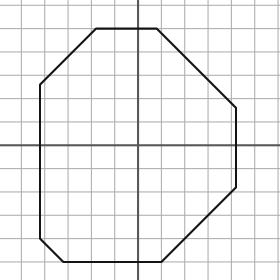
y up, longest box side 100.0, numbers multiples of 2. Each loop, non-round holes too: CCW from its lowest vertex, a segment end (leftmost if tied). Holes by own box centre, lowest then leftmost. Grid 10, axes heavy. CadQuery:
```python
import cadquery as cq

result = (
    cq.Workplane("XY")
    .moveTo(-32.0, -50.0)
    .lineTo(10.0, -50.0)
    .lineTo(42.0, -18.0)
    .lineTo(42.0, 16.0)
    .lineTo(8.0, 50.0)
    .lineTo(-18.0, 50.0)
    .lineTo(-42.0, 26.0)
    .lineTo(-42.0, -40.0)
    .close()
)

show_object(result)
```